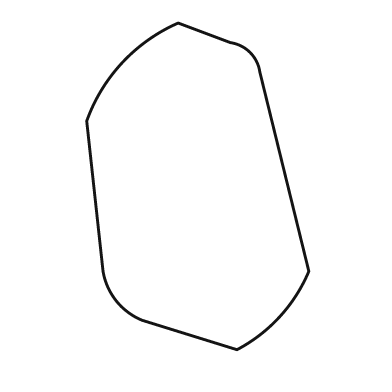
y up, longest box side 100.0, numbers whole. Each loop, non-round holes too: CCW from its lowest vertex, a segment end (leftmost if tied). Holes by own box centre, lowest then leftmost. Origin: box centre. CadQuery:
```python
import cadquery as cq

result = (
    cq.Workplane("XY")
    .moveTo(12.0, -50.0)
    .threePointArc((25.0, -40.0), (34.0, -26.0))
    .lineTo(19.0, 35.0)
    .threePointArc((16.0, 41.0), (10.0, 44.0))
    .lineTo(-6.0, 50.0)
    .threePointArc((-23.0, 38.0), (-34.0, 20.0))
    .lineTo(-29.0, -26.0)
    .threePointArc((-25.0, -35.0), (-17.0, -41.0))
    .close()
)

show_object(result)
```